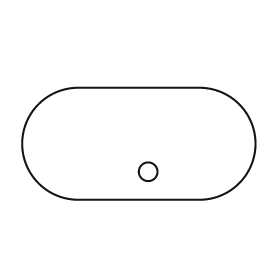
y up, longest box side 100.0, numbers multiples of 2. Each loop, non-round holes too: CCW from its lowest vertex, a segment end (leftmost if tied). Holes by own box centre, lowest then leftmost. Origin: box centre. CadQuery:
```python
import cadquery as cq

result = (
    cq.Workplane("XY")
    .moveTo(-26.0, -24.0)
    .lineTo(26.0, -24.0)
    .threePointArc((50.0, 0.0), (26.0, 24.0))
    .lineTo(-26.0, 24.0)
    .threePointArc((-50.0, 0.0), (-26.0, -24.0))
    .close()
    .moveTo(4.0, -12.0)
    .circle(4.0)
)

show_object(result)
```